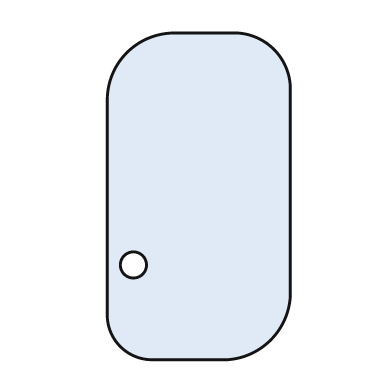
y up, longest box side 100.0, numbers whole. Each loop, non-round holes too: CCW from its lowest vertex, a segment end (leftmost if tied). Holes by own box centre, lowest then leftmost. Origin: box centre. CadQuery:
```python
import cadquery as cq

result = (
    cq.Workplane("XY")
    .moveTo(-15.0, -50.0)
    .lineTo(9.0, -50.0)
    .threePointArc((22.0, -44.0), (28.0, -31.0))
    .lineTo(28.0, 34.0)
    .threePointArc((23.0, 45.0), (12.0, 50.0))
    .lineTo(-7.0, 50.0)
    .threePointArc((-22.0, 44.0), (-28.0, 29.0))
    .lineTo(-28.0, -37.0)
    .threePointArc((-24.0, -46.0), (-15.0, -50.0))
    .close()
    .moveTo(-20.0, -21.0)
    .circle(4.0)
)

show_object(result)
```